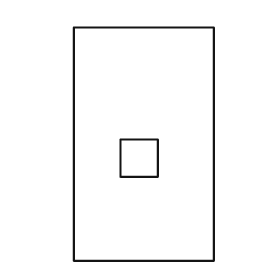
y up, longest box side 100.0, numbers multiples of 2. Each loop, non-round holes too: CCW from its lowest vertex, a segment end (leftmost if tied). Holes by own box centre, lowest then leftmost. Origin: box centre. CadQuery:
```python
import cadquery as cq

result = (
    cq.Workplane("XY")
    .moveTo(-30.0, -50.0)
    .lineTo(30.0, -50.0)
    .lineTo(30.0, 50.0)
    .lineTo(-30.0, 50.0)
    .close()
    .moveTo(-10.0, -14.0)
    .lineTo(6.0, -14.0)
    .lineTo(6.0, 2.0)
    .lineTo(-10.0, 2.0)
    .close()
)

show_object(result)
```